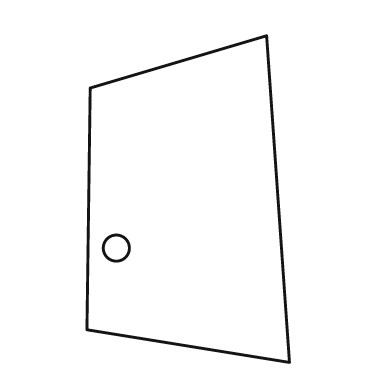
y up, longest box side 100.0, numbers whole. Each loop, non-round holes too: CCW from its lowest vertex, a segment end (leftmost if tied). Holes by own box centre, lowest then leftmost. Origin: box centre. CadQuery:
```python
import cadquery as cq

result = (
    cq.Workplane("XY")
    .moveTo(31.0, -50.0)
    .lineTo(24.0, 50.0)
    .lineTo(-30.0, 34.0)
    .lineTo(-31.0, -40.0)
    .close()
    .moveTo(-22.0, -15.0)
    .circle(4.0)
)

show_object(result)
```